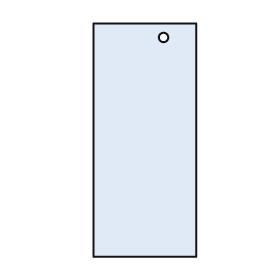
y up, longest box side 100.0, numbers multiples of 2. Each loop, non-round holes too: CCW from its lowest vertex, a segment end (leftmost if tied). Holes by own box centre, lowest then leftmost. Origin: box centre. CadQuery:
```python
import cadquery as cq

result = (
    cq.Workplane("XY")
    .moveTo(-22.0, -50.0)
    .lineTo(22.0, -50.0)
    .lineTo(22.0, 50.0)
    .lineTo(-22.0, 50.0)
    .close()
    .moveTo(8.0, 44.0)
    .circle(2.0)
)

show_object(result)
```